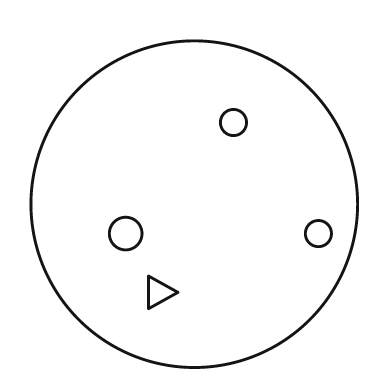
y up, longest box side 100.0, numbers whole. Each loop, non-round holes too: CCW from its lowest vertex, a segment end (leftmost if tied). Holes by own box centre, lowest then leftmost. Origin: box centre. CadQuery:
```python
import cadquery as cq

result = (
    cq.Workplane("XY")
    .moveTo(0.0, 0.0)
    .circle(50.0)
    .moveTo(-14.0, -32.0)
    .lineTo(-5.0, -27.0)
    .lineTo(-14.0, -22.0)
    .close()
    .moveTo(-21.0, -9.0)
    .circle(5.0)
    .moveTo(38.0, -9.0)
    .circle(4.0)
    .moveTo(12.0, 25.0)
    .circle(4.0)
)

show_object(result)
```